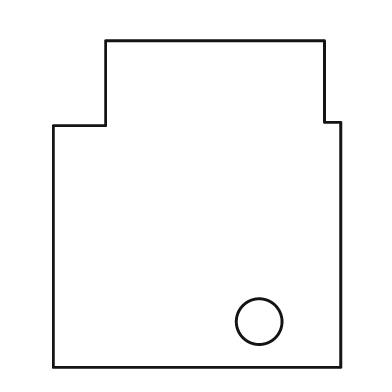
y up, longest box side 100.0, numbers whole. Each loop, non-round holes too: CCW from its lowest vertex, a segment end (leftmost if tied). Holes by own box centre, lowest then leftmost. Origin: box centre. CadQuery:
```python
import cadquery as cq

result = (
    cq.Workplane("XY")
    .moveTo(-44.0, -50.0)
    .lineTo(44.0, -50.0)
    .lineTo(44.0, 25.0)
    .lineTo(39.0, 25.0)
    .lineTo(39.0, 50.0)
    .lineTo(-28.0, 50.0)
    .lineTo(-28.0, 24.0)
    .lineTo(-44.0, 24.0)
    .close()
    .moveTo(19.0, -36.0)
    .circle(7.0)
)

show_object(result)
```